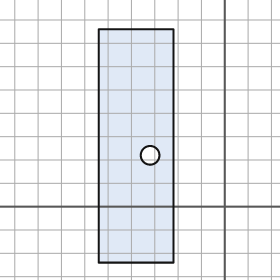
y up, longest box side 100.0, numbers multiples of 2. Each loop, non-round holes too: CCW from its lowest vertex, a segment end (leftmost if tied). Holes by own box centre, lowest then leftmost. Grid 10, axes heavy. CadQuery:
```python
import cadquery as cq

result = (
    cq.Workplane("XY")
    .moveTo(-54.0, -24.0)
    .lineTo(-22.0, -24.0)
    .lineTo(-22.0, 76.0)
    .lineTo(-54.0, 76.0)
    .close()
    .moveTo(-32.0, 22.0)
    .circle(4.0)
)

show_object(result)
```